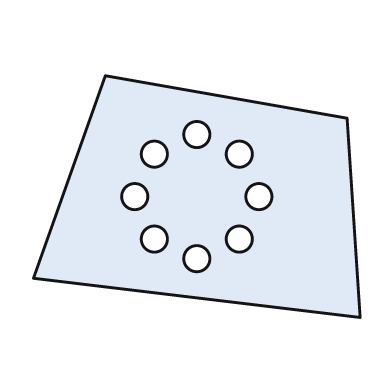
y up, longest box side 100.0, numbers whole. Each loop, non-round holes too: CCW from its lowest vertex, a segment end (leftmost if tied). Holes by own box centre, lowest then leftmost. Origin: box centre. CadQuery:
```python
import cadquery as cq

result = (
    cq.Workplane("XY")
    .moveTo(50.0, -37.0)
    .lineTo(46.0, 24.0)
    .lineTo(-28.0, 37.0)
    .lineTo(-50.0, -25.0)
    .close()
    .moveTo(0.0, -19.0)
    .circle(4.0)
    .moveTo(-13.0, -13.0)
    .circle(4.0)
    .moveTo(13.0, -13.0)
    .circle(4.0)
    .moveTo(-19.0, 0.0)
    .circle(4.0)
    .moveTo(19.0, 0.0)
    .circle(4.0)
    .moveTo(-13.0, 13.0)
    .circle(4.0)
    .moveTo(13.0, 13.0)
    .circle(4.0)
    .moveTo(0.0, 19.0)
    .circle(4.0)
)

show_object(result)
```